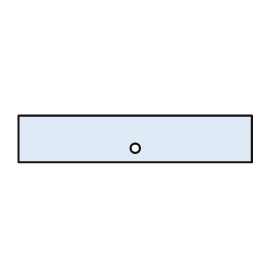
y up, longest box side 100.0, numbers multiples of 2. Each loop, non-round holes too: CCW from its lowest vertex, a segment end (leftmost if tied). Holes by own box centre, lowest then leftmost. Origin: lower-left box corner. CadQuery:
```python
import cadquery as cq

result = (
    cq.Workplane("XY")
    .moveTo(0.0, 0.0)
    .lineTo(100.0, 0.0)
    .lineTo(100.0, 20.0)
    .lineTo(0.0, 20.0)
    .close()
    .moveTo(50.0, 6.0)
    .circle(2.0)
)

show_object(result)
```